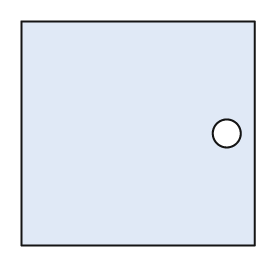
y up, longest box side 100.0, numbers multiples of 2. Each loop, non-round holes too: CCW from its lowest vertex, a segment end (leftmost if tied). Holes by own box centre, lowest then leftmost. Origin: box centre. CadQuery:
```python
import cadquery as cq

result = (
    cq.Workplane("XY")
    .moveTo(-50.0, -48.0)
    .lineTo(50.0, -48.0)
    .lineTo(50.0, 48.0)
    .lineTo(-50.0, 48.0)
    .close()
    .moveTo(38.0, 0.0)
    .circle(6.0)
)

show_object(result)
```